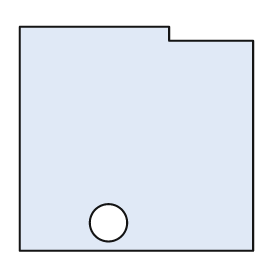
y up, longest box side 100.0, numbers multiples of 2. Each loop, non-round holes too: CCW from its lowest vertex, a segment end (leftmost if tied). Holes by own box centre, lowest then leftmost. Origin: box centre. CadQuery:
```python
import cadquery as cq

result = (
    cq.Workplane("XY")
    .moveTo(-50.0, -48.0)
    .lineTo(50.0, -48.0)
    .lineTo(50.0, 42.0)
    .lineTo(14.0, 42.0)
    .lineTo(14.0, 48.0)
    .lineTo(-50.0, 48.0)
    .close()
    .moveTo(-12.0, -36.0)
    .circle(8.0)
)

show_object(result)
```